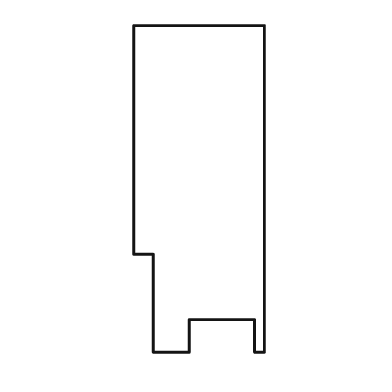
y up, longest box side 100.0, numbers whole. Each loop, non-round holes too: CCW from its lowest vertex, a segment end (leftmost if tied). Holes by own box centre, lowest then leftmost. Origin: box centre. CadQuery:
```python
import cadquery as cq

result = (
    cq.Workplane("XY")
    .moveTo(-14.0, -50.0)
    .lineTo(-3.0, -50.0)
    .lineTo(-3.0, -40.0)
    .lineTo(17.0, -40.0)
    .lineTo(17.0, -50.0)
    .lineTo(20.0, -50.0)
    .lineTo(20.0, 50.0)
    .lineTo(-20.0, 50.0)
    .lineTo(-20.0, -20.0)
    .lineTo(-14.0, -20.0)
    .close()
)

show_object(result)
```